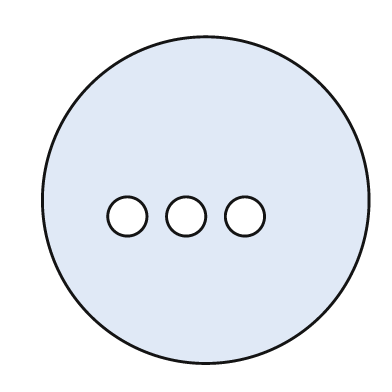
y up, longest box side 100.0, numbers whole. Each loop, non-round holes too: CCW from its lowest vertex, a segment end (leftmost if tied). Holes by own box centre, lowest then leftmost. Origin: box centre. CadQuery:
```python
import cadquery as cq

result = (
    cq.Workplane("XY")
    .moveTo(0.0, 0.0)
    .circle(50.0)
    .moveTo(-24.0, -5.0)
    .circle(6.0)
    .moveTo(-6.0, -5.0)
    .circle(6.0)
    .moveTo(12.0, -5.0)
    .circle(6.0)
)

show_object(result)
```